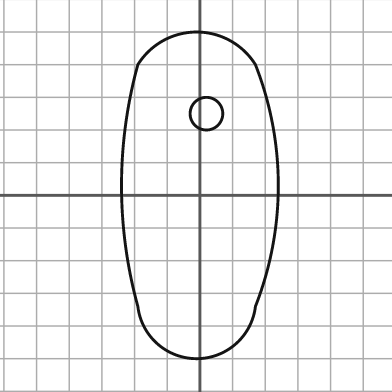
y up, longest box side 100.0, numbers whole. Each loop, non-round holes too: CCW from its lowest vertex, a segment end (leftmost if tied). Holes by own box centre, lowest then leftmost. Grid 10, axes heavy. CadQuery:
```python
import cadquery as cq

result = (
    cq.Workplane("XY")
    .moveTo(-19.0, -34.0)
    .threePointArc((-1.0, -50.0), (17.0, -34.0))
    .threePointArc((24.0, 3.0), (17.0, 40.0))
    .threePointArc((-1.0, 50.0), (-19.0, 40.0))
    .threePointArc((-24.0, 3.0), (-19.0, -34.0))
    .close()
    .moveTo(2.0, 25.0)
    .circle(5.0)
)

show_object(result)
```